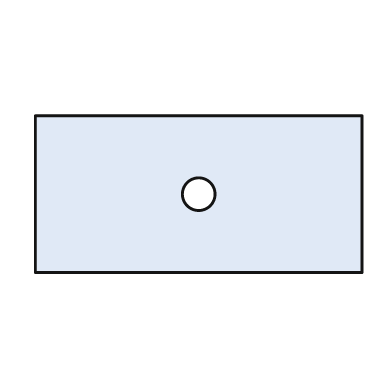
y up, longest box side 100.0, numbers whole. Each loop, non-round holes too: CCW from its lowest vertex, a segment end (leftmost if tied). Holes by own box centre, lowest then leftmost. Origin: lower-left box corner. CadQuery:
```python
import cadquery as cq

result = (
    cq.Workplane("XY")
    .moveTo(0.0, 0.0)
    .lineTo(100.0, 0.0)
    .lineTo(100.0, 48.0)
    .lineTo(0.0, 48.0)
    .close()
    .moveTo(50.0, 24.0)
    .circle(5.0)
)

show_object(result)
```